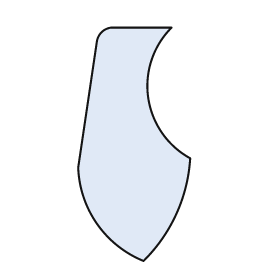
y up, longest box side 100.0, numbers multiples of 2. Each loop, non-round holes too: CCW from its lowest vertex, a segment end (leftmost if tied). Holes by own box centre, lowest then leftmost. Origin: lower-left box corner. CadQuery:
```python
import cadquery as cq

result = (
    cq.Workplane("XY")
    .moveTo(28.0, 0.0)
    .threePointArc((42.0, 20.0), (48.0, 44.0))
    .threePointArc((30.0, 70.0), (40.0, 100.0))
    .lineTo(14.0, 100.0)
    .threePointArc((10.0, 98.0), (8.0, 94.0))
    .lineTo(0.0, 40.0)
    .threePointArc((8.0, 16.0), (28.0, 0.0))
    .close()
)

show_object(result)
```